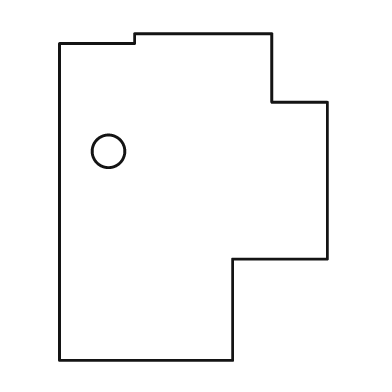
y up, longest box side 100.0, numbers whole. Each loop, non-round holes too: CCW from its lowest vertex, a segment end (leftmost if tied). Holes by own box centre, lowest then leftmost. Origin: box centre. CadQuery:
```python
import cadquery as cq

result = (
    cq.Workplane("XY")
    .moveTo(-41.0, -50.0)
    .lineTo(12.0, -50.0)
    .lineTo(12.0, -19.0)
    .lineTo(41.0, -19.0)
    .lineTo(41.0, 29.0)
    .lineTo(24.0, 29.0)
    .lineTo(24.0, 50.0)
    .lineTo(-18.0, 50.0)
    .lineTo(-18.0, 47.0)
    .lineTo(-41.0, 47.0)
    .close()
    .moveTo(-26.0, 14.0)
    .circle(5.0)
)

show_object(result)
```